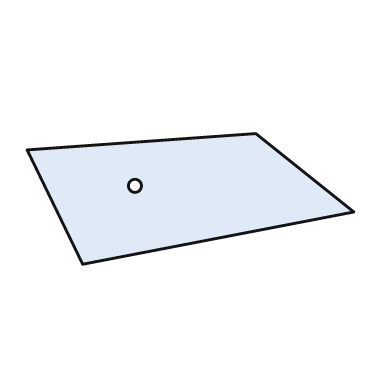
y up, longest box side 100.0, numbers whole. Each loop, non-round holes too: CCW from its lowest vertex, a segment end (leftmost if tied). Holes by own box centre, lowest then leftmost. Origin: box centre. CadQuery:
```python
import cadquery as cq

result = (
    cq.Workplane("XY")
    .moveTo(-33.0, -20.0)
    .lineTo(50.0, -4.0)
    .lineTo(20.0, 20.0)
    .lineTo(-50.0, 15.0)
    .close()
    .moveTo(-17.0, 4.0)
    .circle(2.0)
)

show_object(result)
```